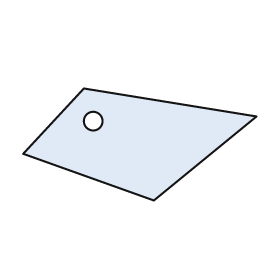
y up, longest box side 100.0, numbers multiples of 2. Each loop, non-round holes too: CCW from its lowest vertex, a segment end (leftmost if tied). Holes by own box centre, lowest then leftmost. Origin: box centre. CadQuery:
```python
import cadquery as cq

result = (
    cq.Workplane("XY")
    .moveTo(6.0, -24.0)
    .lineTo(50.0, 12.0)
    .lineTo(-24.0, 24.0)
    .lineTo(-50.0, -4.0)
    .close()
    .moveTo(-20.0, 10.0)
    .circle(4.0)
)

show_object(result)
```